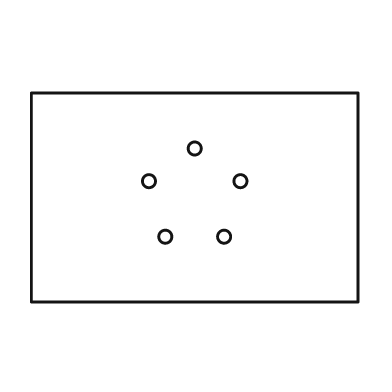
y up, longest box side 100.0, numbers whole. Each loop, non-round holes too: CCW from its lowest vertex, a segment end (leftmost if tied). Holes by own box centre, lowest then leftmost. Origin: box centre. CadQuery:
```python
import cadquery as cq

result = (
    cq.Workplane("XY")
    .moveTo(-50.0, -32.0)
    .lineTo(50.0, -32.0)
    .lineTo(50.0, 32.0)
    .lineTo(-50.0, 32.0)
    .close()
    .moveTo(-9.0, -12.0)
    .circle(2.0)
    .moveTo(9.0, -12.0)
    .circle(2.0)
    .moveTo(-14.0, 5.0)
    .circle(2.0)
    .moveTo(14.0, 5.0)
    .circle(2.0)
    .moveTo(0.0, 15.0)
    .circle(2.0)
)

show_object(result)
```